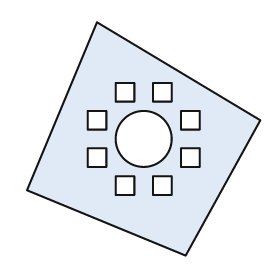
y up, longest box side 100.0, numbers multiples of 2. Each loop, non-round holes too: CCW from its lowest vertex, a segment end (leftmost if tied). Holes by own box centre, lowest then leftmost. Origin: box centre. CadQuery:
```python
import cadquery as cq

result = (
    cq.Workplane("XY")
    .moveTo(18.0, -50.0)
    .lineTo(50.0, 8.0)
    .lineTo(-20.0, 50.0)
    .lineTo(-50.0, -22.0)
    .close()
    .moveTo(-12.0, -24.0)
    .lineTo(-4.0, -24.0)
    .lineTo(-4.0, -16.0)
    .lineTo(-12.0, -16.0)
    .close()
    .moveTo(4.0, -24.0)
    .lineTo(12.0, -24.0)
    .lineTo(12.0, -16.0)
    .lineTo(4.0, -16.0)
    .close()
    .moveTo(-24.0, -12.0)
    .lineTo(-16.0, -12.0)
    .lineTo(-16.0, -4.0)
    .lineTo(-24.0, -4.0)
    .close()
    .moveTo(16.0, -12.0)
    .lineTo(24.0, -12.0)
    .lineTo(24.0, -4.0)
    .lineTo(16.0, -4.0)
    .close()
    .moveTo(0.0, 0.0)
    .circle(12.0)
    .moveTo(-24.0, 4.0)
    .lineTo(-16.0, 4.0)
    .lineTo(-16.0, 12.0)
    .lineTo(-24.0, 12.0)
    .close()
    .moveTo(16.0, 4.0)
    .lineTo(24.0, 4.0)
    .lineTo(24.0, 12.0)
    .lineTo(16.0, 12.0)
    .close()
    .moveTo(-12.0, 16.0)
    .lineTo(-4.0, 16.0)
    .lineTo(-4.0, 24.0)
    .lineTo(-12.0, 24.0)
    .close()
    .moveTo(4.0, 16.0)
    .lineTo(12.0, 16.0)
    .lineTo(12.0, 24.0)
    .lineTo(4.0, 24.0)
    .close()
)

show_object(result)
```